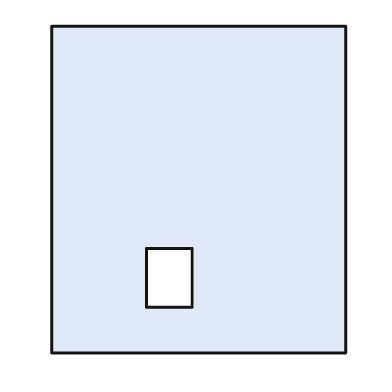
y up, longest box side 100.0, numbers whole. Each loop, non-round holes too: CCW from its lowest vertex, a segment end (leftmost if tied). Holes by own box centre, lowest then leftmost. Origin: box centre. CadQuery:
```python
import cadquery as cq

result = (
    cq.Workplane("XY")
    .moveTo(-45.0, -50.0)
    .lineTo(45.0, -50.0)
    .lineTo(45.0, 50.0)
    .lineTo(-45.0, 50.0)
    .close()
    .moveTo(-16.0, -36.0)
    .lineTo(-2.0, -36.0)
    .lineTo(-2.0, -18.0)
    .lineTo(-16.0, -18.0)
    .close()
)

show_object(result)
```